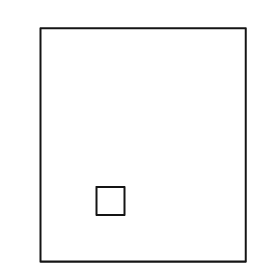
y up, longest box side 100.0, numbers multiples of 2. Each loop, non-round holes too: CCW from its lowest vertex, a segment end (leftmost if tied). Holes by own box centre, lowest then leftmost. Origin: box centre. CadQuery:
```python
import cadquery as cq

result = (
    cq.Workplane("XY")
    .moveTo(-44.0, -50.0)
    .lineTo(44.0, -50.0)
    .lineTo(44.0, 50.0)
    .lineTo(-44.0, 50.0)
    .close()
    .moveTo(-20.0, -30.0)
    .lineTo(-8.0, -30.0)
    .lineTo(-8.0, -18.0)
    .lineTo(-20.0, -18.0)
    .close()
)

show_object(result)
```